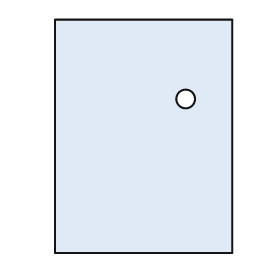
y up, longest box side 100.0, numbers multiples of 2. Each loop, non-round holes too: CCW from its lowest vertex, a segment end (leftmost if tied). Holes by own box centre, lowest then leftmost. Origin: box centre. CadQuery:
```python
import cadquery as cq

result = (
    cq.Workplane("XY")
    .moveTo(-38.0, -50.0)
    .lineTo(38.0, -50.0)
    .lineTo(38.0, 50.0)
    .lineTo(-38.0, 50.0)
    .close()
    .moveTo(18.0, 16.0)
    .circle(4.0)
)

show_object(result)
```